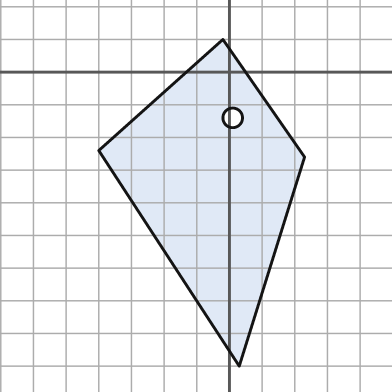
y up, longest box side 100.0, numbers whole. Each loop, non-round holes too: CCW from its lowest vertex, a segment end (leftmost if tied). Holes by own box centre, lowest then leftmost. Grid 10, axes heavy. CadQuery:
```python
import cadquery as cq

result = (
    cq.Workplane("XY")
    .moveTo(3.0, -90.0)
    .lineTo(23.0, -26.0)
    .lineTo(-2.0, 10.0)
    .lineTo(-40.0, -24.0)
    .close()
    .moveTo(1.0, -14.0)
    .circle(3.0)
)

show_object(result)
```